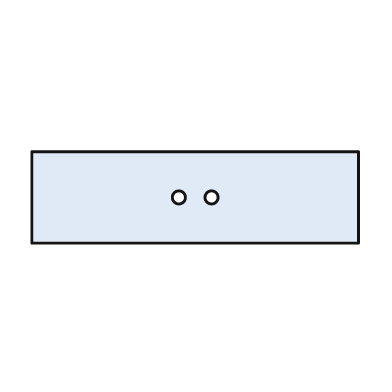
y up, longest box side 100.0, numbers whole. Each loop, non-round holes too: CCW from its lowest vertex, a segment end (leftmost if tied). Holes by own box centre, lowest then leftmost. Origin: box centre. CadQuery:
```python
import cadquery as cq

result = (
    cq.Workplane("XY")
    .moveTo(-50.0, -14.0)
    .lineTo(50.0, -14.0)
    .lineTo(50.0, 14.0)
    .lineTo(-50.0, 14.0)
    .close()
    .moveTo(-5.0, 0.0)
    .circle(2.0)
    .moveTo(5.0, 0.0)
    .circle(2.0)
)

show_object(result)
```